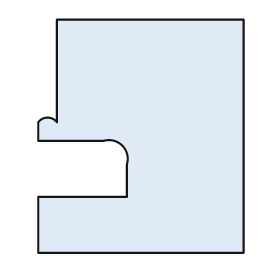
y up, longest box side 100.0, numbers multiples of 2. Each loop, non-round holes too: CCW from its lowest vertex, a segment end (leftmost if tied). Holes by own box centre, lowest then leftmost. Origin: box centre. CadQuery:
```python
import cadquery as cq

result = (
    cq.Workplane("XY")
    .moveTo(-44.0, -50.0)
    .lineTo(44.0, -50.0)
    .lineTo(44.0, 50.0)
    .lineTo(-36.0, 50.0)
    .lineTo(-36.0, 6.0)
    .threePointArc((-40.0, 8.0), (-44.0, 6.0))
    .lineTo(-44.0, -2.0)
    .lineTo(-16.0, -2.0)
    .threePointArc((-8.0, -4.0), (-6.0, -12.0))
    .lineTo(-6.0, -26.0)
    .lineTo(-44.0, -26.0)
    .close()
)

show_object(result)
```